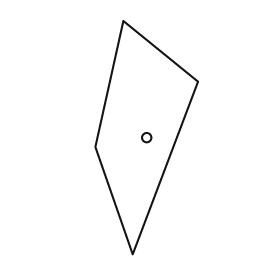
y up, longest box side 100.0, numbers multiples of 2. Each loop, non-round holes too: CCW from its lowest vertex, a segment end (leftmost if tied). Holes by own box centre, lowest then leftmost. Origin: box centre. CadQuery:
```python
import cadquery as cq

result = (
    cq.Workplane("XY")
    .moveTo(-6.0, -50.0)
    .lineTo(22.0, 24.0)
    .lineTo(-10.0, 50.0)
    .lineTo(-22.0, -4.0)
    .close()
    .moveTo(0.0, 0.0)
    .circle(2.0)
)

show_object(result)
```